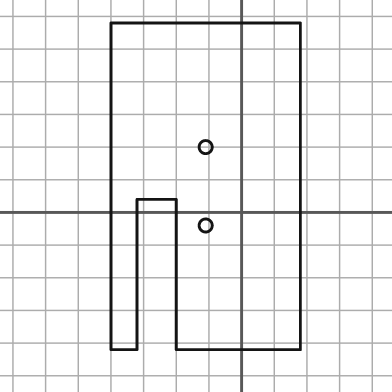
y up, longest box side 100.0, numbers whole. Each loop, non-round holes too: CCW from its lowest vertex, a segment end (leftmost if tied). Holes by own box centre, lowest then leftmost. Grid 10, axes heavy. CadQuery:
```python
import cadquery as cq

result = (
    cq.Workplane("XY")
    .moveTo(-40.0, -42.0)
    .lineTo(-32.0, -42.0)
    .lineTo(-32.0, 4.0)
    .lineTo(-20.0, 4.0)
    .lineTo(-20.0, -42.0)
    .lineTo(18.0, -42.0)
    .lineTo(18.0, 58.0)
    .lineTo(-40.0, 58.0)
    .close()
    .moveTo(-11.0, -4.0)
    .circle(2.0)
    .moveTo(-11.0, 20.0)
    .circle(2.0)
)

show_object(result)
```